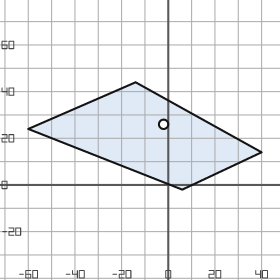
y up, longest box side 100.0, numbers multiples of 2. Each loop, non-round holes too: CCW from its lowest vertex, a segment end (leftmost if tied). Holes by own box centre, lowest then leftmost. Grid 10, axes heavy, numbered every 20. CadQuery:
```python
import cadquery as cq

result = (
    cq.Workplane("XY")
    .moveTo(6.0, -2.0)
    .lineTo(40.0, 14.0)
    .lineTo(-14.0, 44.0)
    .lineTo(-60.0, 24.0)
    .close()
    .moveTo(-2.0, 26.0)
    .circle(2.0)
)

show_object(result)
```